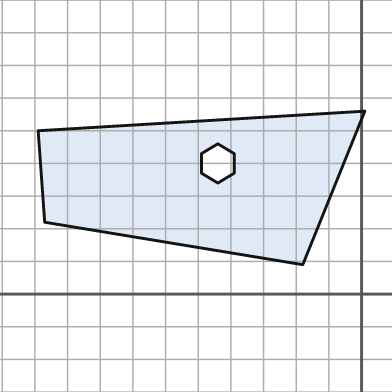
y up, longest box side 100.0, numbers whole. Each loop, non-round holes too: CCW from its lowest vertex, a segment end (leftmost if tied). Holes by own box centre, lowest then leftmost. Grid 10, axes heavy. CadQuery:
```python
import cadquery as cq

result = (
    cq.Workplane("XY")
    .moveTo(-18.0, 9.0)
    .lineTo(1.0, 56.0)
    .lineTo(-99.0, 50.0)
    .lineTo(-97.0, 22.0)
    .close()
    .moveTo(-44.0, 34.0)
    .lineTo(-39.0, 37.0)
    .lineTo(-39.0, 43.0)
    .lineTo(-44.0, 46.0)
    .lineTo(-49.0, 43.0)
    .lineTo(-49.0, 37.0)
    .close()
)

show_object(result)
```